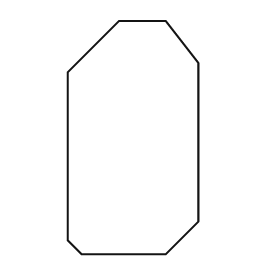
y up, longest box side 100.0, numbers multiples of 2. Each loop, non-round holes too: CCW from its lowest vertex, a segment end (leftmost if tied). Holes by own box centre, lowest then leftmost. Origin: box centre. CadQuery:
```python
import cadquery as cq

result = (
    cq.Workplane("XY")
    .moveTo(-22.0, -50.0)
    .lineTo(14.0, -50.0)
    .lineTo(28.0, -36.0)
    .lineTo(28.0, 32.0)
    .lineTo(14.0, 50.0)
    .lineTo(-6.0, 50.0)
    .lineTo(-28.0, 28.0)
    .lineTo(-28.0, -44.0)
    .close()
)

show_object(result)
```